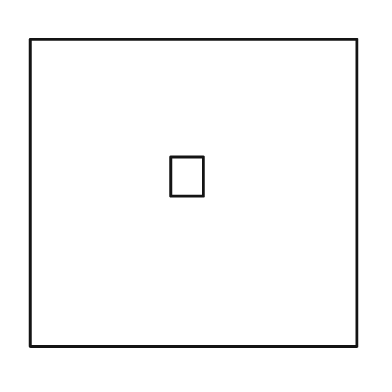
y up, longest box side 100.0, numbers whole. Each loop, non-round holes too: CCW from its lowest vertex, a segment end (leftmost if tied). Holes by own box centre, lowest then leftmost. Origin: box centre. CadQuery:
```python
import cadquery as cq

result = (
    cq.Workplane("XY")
    .moveTo(-50.0, -47.0)
    .lineTo(50.0, -47.0)
    .lineTo(50.0, 47.0)
    .lineTo(-50.0, 47.0)
    .close()
    .moveTo(-7.0, -1.0)
    .lineTo(3.0, -1.0)
    .lineTo(3.0, 11.0)
    .lineTo(-7.0, 11.0)
    .close()
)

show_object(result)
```